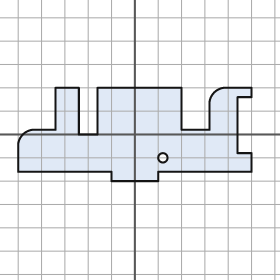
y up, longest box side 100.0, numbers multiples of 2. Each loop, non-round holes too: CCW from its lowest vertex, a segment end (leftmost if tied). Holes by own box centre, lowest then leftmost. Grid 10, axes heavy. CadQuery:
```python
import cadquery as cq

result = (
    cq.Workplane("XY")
    .moveTo(-10.0, -20.0)
    .lineTo(10.0, -20.0)
    .lineTo(10.0, -16.0)
    .lineTo(50.0, -16.0)
    .lineTo(50.0, -8.0)
    .lineTo(44.0, -8.0)
    .lineTo(44.0, 16.0)
    .lineTo(50.0, 16.0)
    .lineTo(50.0, 20.0)
    .lineTo(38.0, 20.0)
    .threePointArc((34.0, 18.0), (32.0, 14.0))
    .lineTo(32.0, 2.0)
    .lineTo(20.0, 2.0)
    .lineTo(20.0, 20.0)
    .lineTo(-16.0, 20.0)
    .lineTo(-16.0, 0.0)
    .lineTo(-24.0, 0.0)
    .lineTo(-24.0, 20.0)
    .lineTo(-34.0, 20.0)
    .lineTo(-34.0, 2.0)
    .lineTo(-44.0, 2.0)
    .threePointArc((-48.0, 0.0), (-50.0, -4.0))
    .lineTo(-50.0, -16.0)
    .lineTo(-10.0, -16.0)
    .close()
    .moveTo(12.0, -10.0)
    .circle(2.0)
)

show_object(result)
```